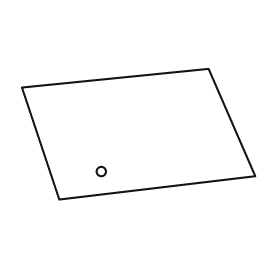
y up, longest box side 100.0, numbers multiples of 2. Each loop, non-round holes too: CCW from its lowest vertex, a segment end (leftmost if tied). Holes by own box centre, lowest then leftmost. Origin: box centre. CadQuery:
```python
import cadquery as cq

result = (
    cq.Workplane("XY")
    .moveTo(-34.0, -28.0)
    .lineTo(50.0, -18.0)
    .lineTo(30.0, 28.0)
    .lineTo(-50.0, 20.0)
    .close()
    .moveTo(-16.0, -16.0)
    .circle(2.0)
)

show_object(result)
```